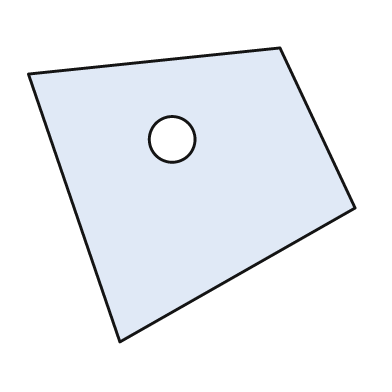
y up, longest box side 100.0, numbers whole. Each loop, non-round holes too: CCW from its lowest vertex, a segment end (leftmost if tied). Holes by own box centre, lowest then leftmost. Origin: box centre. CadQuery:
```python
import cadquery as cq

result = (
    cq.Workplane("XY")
    .moveTo(-22.0, -45.0)
    .lineTo(50.0, -4.0)
    .lineTo(27.0, 45.0)
    .lineTo(-50.0, 37.0)
    .close()
    .moveTo(-6.0, 17.0)
    .circle(7.0)
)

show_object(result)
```